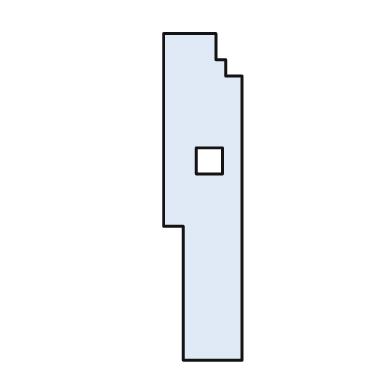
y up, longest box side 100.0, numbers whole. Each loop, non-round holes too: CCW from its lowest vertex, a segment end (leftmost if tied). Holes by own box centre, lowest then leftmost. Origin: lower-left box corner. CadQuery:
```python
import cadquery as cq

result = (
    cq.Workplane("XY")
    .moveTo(6.0, 0.0)
    .lineTo(24.0, 0.0)
    .lineTo(24.0, 87.0)
    .lineTo(19.0, 87.0)
    .lineTo(19.0, 92.0)
    .lineTo(16.0, 92.0)
    .lineTo(16.0, 100.0)
    .lineTo(0.0, 100.0)
    .lineTo(0.0, 41.0)
    .lineTo(6.0, 41.0)
    .close()
    .moveTo(10.0, 57.0)
    .lineTo(18.0, 57.0)
    .lineTo(18.0, 65.0)
    .lineTo(10.0, 65.0)
    .close()
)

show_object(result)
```